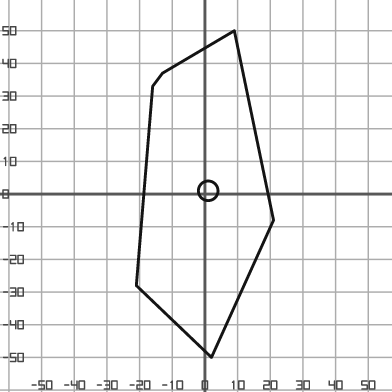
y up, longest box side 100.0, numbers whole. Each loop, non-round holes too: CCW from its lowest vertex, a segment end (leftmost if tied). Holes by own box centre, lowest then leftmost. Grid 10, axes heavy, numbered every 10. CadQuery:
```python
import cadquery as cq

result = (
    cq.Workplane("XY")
    .moveTo(2.0, -50.0)
    .lineTo(21.0, -8.0)
    .lineTo(9.0, 50.0)
    .lineTo(-13.0, 37.0)
    .lineTo(-16.0, 33.0)
    .lineTo(-21.0, -28.0)
    .close()
    .moveTo(1.0, 1.0)
    .circle(3.0)
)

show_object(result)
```